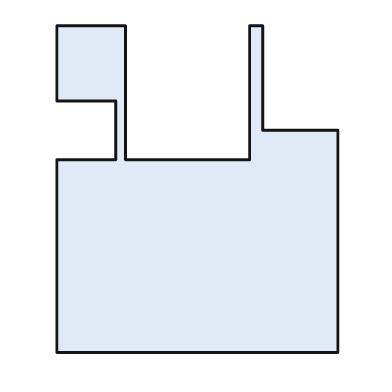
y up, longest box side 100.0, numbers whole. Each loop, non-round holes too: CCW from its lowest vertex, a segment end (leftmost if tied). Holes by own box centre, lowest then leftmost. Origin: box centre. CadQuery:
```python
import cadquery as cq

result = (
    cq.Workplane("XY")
    .moveTo(-43.0, -50.0)
    .lineTo(43.0, -50.0)
    .lineTo(43.0, 18.0)
    .lineTo(20.0, 18.0)
    .lineTo(20.0, 50.0)
    .lineTo(16.0, 50.0)
    .lineTo(16.0, 9.0)
    .lineTo(-22.0, 9.0)
    .lineTo(-22.0, 50.0)
    .lineTo(-43.0, 50.0)
    .lineTo(-43.0, 27.0)
    .lineTo(-25.0, 27.0)
    .lineTo(-25.0, 9.0)
    .lineTo(-43.0, 9.0)
    .close()
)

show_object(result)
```